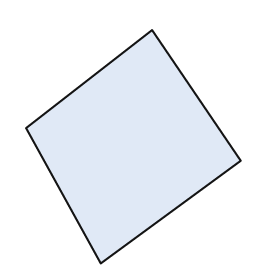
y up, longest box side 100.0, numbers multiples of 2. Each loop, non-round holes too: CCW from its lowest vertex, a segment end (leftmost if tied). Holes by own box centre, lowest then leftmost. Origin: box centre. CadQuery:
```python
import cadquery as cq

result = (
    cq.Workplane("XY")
    .moveTo(-14.0, -50.0)
    .lineTo(46.0, -6.0)
    .lineTo(8.0, 50.0)
    .lineTo(-46.0, 8.0)
    .close()
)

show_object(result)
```